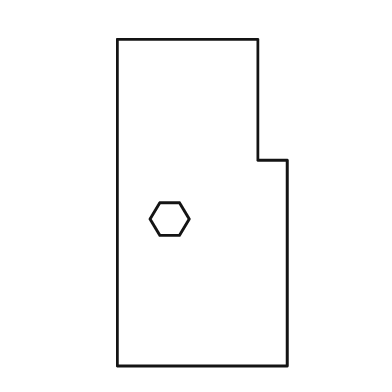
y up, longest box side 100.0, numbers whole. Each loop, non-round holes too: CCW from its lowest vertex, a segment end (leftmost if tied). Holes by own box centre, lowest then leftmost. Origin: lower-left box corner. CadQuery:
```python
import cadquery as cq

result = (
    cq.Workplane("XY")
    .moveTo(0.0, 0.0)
    .lineTo(52.0, 0.0)
    .lineTo(52.0, 63.0)
    .lineTo(43.0, 63.0)
    .lineTo(43.0, 100.0)
    .lineTo(0.0, 100.0)
    .close()
    .moveTo(13.0, 40.0)
    .lineTo(19.0, 40.0)
    .lineTo(22.0, 45.0)
    .lineTo(19.0, 50.0)
    .lineTo(13.0, 50.0)
    .lineTo(10.0, 45.0)
    .close()
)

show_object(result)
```